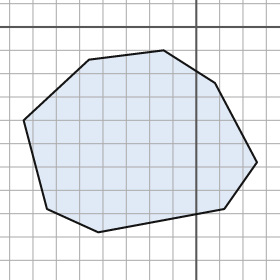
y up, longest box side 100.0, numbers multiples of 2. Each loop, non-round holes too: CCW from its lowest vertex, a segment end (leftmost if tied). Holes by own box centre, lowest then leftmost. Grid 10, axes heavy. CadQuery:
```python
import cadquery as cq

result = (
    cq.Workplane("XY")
    .moveTo(-42.0, -88.0)
    .lineTo(12.0, -78.0)
    .lineTo(26.0, -58.0)
    .lineTo(8.0, -24.0)
    .lineTo(-14.0, -10.0)
    .lineTo(-46.0, -14.0)
    .lineTo(-74.0, -40.0)
    .lineTo(-64.0, -78.0)
    .close()
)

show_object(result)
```